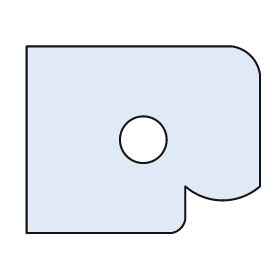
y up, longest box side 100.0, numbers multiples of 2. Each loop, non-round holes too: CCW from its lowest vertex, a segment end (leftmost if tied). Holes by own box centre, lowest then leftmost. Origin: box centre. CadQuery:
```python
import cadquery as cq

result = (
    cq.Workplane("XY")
    .moveTo(-50.0, -40.0)
    .lineTo(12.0, -40.0)
    .threePointArc((16.0, -38.0), (18.0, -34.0))
    .lineTo(18.0, -20.0)
    .threePointArc((34.0, -26.0), (50.0, -20.0))
    .lineTo(50.0, 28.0)
    .threePointArc((46.0, 36.0), (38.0, 40.0))
    .lineTo(-50.0, 40.0)
    .close()
    .moveTo(0.0, 0.0)
    .circle(10.0)
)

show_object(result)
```